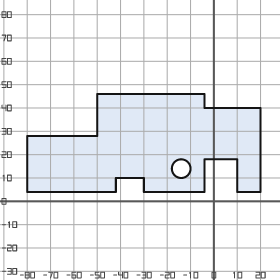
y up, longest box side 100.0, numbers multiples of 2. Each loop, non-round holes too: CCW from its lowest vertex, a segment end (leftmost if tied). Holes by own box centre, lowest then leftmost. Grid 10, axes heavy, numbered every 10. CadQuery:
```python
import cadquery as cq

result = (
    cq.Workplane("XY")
    .moveTo(-80.0, 4.0)
    .lineTo(-42.0, 4.0)
    .lineTo(-42.0, 10.0)
    .lineTo(-30.0, 10.0)
    .lineTo(-30.0, 4.0)
    .lineTo(-4.0, 4.0)
    .lineTo(-4.0, 18.0)
    .lineTo(10.0, 18.0)
    .lineTo(10.0, 4.0)
    .lineTo(20.0, 4.0)
    .lineTo(20.0, 40.0)
    .lineTo(-4.0, 40.0)
    .lineTo(-4.0, 46.0)
    .lineTo(-50.0, 46.0)
    .lineTo(-50.0, 28.0)
    .lineTo(-80.0, 28.0)
    .close()
    .moveTo(-14.0, 14.0)
    .circle(4.0)
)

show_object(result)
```